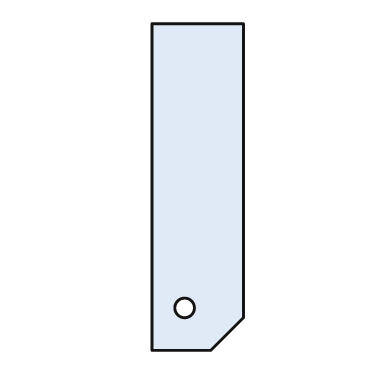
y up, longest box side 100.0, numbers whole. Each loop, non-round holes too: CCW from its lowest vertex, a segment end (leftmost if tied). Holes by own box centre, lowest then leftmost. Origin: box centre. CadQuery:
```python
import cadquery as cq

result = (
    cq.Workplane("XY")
    .moveTo(-14.0, -50.0)
    .lineTo(4.0, -50.0)
    .lineTo(14.0, -40.0)
    .lineTo(14.0, 50.0)
    .lineTo(-14.0, 50.0)
    .close()
    .moveTo(-4.0, -37.0)
    .circle(3.0)
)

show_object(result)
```